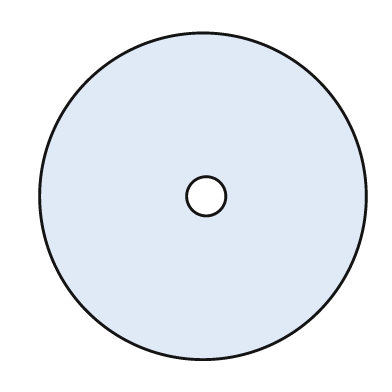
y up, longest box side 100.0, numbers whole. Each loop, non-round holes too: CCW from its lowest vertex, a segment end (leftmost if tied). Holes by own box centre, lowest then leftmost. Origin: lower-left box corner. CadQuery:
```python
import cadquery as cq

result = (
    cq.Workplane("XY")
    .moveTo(50.0, 50.0)
    .circle(50.0)
    .moveTo(51.0, 50.0)
    .circle(6.0)
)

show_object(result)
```